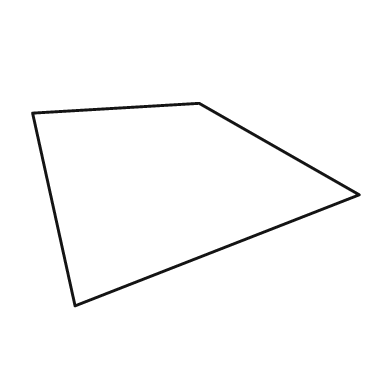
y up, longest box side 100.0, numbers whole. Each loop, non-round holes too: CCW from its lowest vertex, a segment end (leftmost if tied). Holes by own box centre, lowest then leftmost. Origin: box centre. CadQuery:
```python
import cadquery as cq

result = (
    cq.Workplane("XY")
    .moveTo(-37.0, -31.0)
    .lineTo(50.0, 3.0)
    .lineTo(1.0, 31.0)
    .lineTo(-50.0, 28.0)
    .close()
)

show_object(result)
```